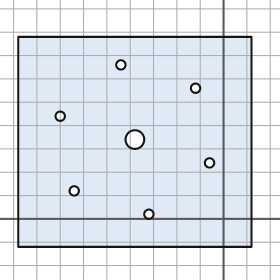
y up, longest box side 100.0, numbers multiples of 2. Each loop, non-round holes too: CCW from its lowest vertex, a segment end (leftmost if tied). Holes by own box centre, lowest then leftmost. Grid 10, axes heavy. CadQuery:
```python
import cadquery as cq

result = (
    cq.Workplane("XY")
    .moveTo(-88.0, -12.0)
    .lineTo(12.0, -12.0)
    .lineTo(12.0, 78.0)
    .lineTo(-88.0, 78.0)
    .close()
    .moveTo(-32.0, 2.0)
    .circle(2.0)
    .moveTo(-64.0, 12.0)
    .circle(2.0)
    .moveTo(-6.0, 24.0)
    .circle(2.0)
    .moveTo(-38.0, 34.0)
    .circle(4.0)
    .moveTo(-70.0, 44.0)
    .circle(2.0)
    .moveTo(-12.0, 56.0)
    .circle(2.0)
    .moveTo(-44.0, 66.0)
    .circle(2.0)
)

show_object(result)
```